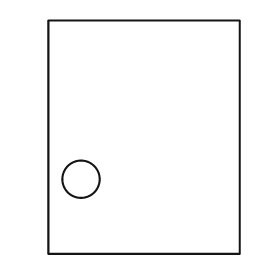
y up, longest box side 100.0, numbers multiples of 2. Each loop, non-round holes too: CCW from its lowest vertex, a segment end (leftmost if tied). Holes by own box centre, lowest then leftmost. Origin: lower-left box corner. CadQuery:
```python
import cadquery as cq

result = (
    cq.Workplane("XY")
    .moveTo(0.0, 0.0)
    .lineTo(82.0, 0.0)
    .lineTo(82.0, 100.0)
    .lineTo(0.0, 100.0)
    .close()
    .moveTo(14.0, 32.0)
    .circle(8.0)
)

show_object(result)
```